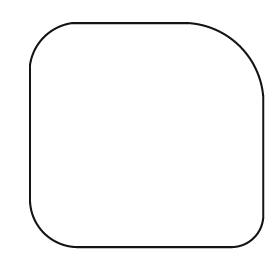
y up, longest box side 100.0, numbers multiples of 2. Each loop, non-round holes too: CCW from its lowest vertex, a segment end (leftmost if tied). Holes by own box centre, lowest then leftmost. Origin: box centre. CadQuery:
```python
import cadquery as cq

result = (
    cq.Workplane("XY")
    .moveTo(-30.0, -48.0)
    .lineTo(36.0, -48.0)
    .threePointArc((46.0, -44.0), (50.0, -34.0))
    .lineTo(50.0, 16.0)
    .threePointArc((40.0, 38.0), (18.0, 48.0))
    .lineTo(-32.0, 48.0)
    .threePointArc((-44.0, 42.0), (-50.0, 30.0))
    .lineTo(-50.0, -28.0)
    .threePointArc((-44.0, -42.0), (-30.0, -48.0))
    .close()
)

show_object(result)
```